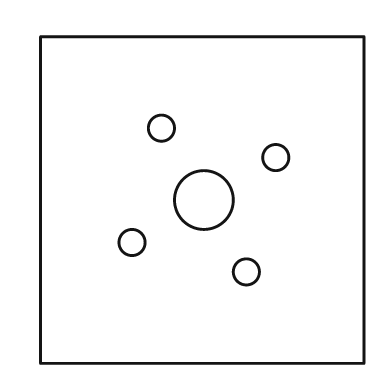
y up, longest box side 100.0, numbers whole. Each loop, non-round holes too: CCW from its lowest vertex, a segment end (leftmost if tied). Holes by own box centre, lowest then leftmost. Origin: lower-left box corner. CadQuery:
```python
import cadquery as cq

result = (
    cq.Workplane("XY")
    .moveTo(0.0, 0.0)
    .lineTo(99.0, 0.0)
    .lineTo(99.0, 100.0)
    .lineTo(0.0, 100.0)
    .close()
    .moveTo(63.0, 28.0)
    .circle(4.0)
    .moveTo(28.0, 37.0)
    .circle(4.0)
    .moveTo(50.0, 50.0)
    .circle(9.0)
    .moveTo(72.0, 63.0)
    .circle(4.0)
    .moveTo(37.0, 72.0)
    .circle(4.0)
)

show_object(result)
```